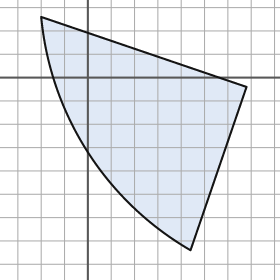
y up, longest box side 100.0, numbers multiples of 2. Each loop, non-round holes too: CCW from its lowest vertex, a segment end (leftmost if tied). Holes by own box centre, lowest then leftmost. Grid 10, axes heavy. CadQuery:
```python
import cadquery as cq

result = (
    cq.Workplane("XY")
    .moveTo(44.0, -74.0)
    .lineTo(68.0, -4.0)
    .lineTo(-20.0, 26.0)
    .threePointArc((0.0, -32.0), (44.0, -74.0))
    .close()
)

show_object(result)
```